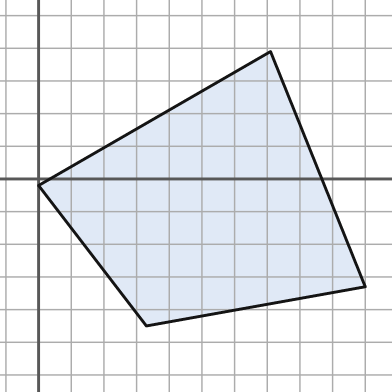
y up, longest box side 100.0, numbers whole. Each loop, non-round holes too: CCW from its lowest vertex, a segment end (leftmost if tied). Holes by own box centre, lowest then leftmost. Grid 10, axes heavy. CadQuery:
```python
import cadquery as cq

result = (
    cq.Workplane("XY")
    .moveTo(33.0, -45.0)
    .lineTo(100.0, -33.0)
    .lineTo(71.0, 39.0)
    .lineTo(0.0, -2.0)
    .close()
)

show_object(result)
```